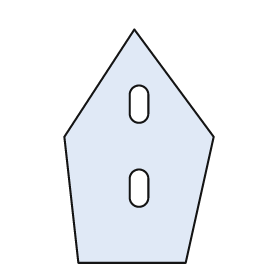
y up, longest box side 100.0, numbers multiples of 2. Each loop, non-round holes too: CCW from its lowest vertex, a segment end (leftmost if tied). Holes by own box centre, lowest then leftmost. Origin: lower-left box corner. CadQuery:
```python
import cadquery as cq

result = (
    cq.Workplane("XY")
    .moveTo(6.0, 0.0)
    .lineTo(52.0, 0.0)
    .lineTo(64.0, 54.0)
    .lineTo(30.0, 100.0)
    .lineTo(0.0, 54.0)
    .close()
    .moveTo(28.0, 28.0)
    .threePointArc((32.0, 24.0), (36.0, 28.0))
    .lineTo(36.0, 36.0)
    .threePointArc((32.0, 40.0), (28.0, 36.0))
    .close()
    .moveTo(28.0, 64.0)
    .threePointArc((32.0, 60.0), (36.0, 64.0))
    .lineTo(36.0, 72.0)
    .threePointArc((32.0, 76.0), (28.0, 72.0))
    .close()
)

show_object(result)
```